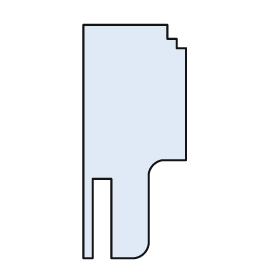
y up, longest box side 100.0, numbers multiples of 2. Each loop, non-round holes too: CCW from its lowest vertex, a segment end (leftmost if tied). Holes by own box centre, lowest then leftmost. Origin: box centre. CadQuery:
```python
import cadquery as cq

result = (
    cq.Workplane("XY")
    .moveTo(-22.0, -50.0)
    .lineTo(-18.0, -50.0)
    .lineTo(-18.0, -16.0)
    .lineTo(-10.0, -16.0)
    .lineTo(-10.0, -50.0)
    .lineTo(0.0, -50.0)
    .threePointArc((4.0, -48.0), (6.0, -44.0))
    .lineTo(6.0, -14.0)
    .threePointArc((8.0, -10.0), (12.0, -8.0))
    .lineTo(22.0, -8.0)
    .lineTo(22.0, 40.0)
    .lineTo(18.0, 40.0)
    .lineTo(18.0, 44.0)
    .lineTo(14.0, 44.0)
    .lineTo(14.0, 50.0)
    .lineTo(-22.0, 50.0)
    .close()
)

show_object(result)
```